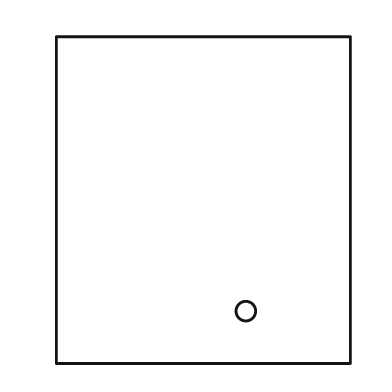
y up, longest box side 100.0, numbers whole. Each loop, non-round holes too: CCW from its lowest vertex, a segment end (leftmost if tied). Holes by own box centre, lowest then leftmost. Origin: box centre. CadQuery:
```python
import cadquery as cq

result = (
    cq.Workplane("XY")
    .moveTo(-45.0, -50.0)
    .lineTo(45.0, -50.0)
    .lineTo(45.0, 50.0)
    .lineTo(-45.0, 50.0)
    .close()
    .moveTo(13.0, -34.0)
    .circle(3.0)
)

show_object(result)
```